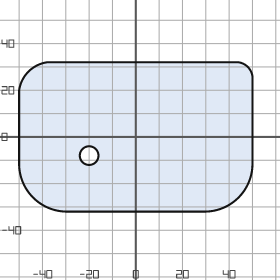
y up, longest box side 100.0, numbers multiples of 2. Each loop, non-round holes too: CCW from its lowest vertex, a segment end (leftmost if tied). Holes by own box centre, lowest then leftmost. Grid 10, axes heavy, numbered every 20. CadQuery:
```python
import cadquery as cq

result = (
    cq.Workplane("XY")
    .moveTo(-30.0, -32.0)
    .lineTo(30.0, -32.0)
    .threePointArc((44.0, -26.0), (50.0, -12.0))
    .lineTo(50.0, 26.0)
    .threePointArc((48.0, 30.0), (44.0, 32.0))
    .lineTo(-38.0, 32.0)
    .threePointArc((-46.0, 28.0), (-50.0, 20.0))
    .lineTo(-50.0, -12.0)
    .threePointArc((-44.0, -26.0), (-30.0, -32.0))
    .close()
    .moveTo(-20.0, -8.0)
    .circle(4.0)
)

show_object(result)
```